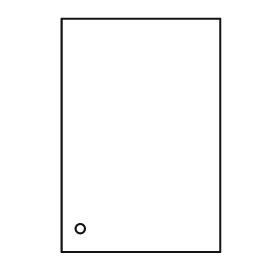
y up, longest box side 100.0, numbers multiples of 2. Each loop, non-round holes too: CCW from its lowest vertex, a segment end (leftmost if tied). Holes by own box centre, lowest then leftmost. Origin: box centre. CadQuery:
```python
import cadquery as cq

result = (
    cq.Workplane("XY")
    .moveTo(-34.0, -50.0)
    .lineTo(34.0, -50.0)
    .lineTo(34.0, 50.0)
    .lineTo(-34.0, 50.0)
    .close()
    .moveTo(-26.0, -40.0)
    .circle(2.0)
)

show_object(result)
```